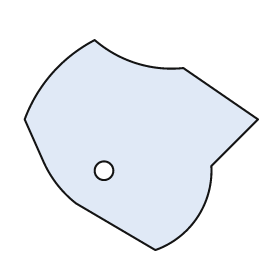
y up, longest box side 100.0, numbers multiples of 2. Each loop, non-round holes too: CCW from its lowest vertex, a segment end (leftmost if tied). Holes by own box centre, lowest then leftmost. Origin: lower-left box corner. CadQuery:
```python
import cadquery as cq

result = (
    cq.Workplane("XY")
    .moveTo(56.0, 0.0)
    .threePointArc((74.0, 14.0), (80.0, 36.0))
    .lineTo(100.0, 56.0)
    .lineTo(68.0, 78.0)
    .threePointArc((48.0, 80.0), (30.0, 90.0))
    .threePointArc((12.0, 76.0), (0.0, 56.0))
    .lineTo(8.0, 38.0)
    .threePointArc((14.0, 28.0), (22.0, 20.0))
    .close()
    .moveTo(34.0, 34.0)
    .circle(4.0)
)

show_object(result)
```